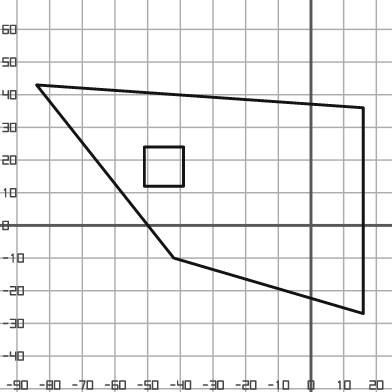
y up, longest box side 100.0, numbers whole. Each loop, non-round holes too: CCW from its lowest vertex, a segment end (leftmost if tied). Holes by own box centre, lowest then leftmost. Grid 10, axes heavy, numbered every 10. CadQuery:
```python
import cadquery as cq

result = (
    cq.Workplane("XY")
    .moveTo(16.0, -27.0)
    .lineTo(16.0, 36.0)
    .lineTo(-84.0, 43.0)
    .lineTo(-42.0, -10.0)
    .close()
    .moveTo(-51.0, 12.0)
    .lineTo(-39.0, 12.0)
    .lineTo(-39.0, 24.0)
    .lineTo(-51.0, 24.0)
    .close()
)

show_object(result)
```